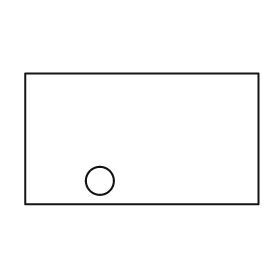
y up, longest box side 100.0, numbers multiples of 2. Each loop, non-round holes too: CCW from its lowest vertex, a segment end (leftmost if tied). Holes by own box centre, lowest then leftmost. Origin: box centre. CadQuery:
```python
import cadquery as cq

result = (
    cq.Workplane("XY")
    .moveTo(-50.0, -28.0)
    .lineTo(50.0, -28.0)
    .lineTo(50.0, 28.0)
    .lineTo(-50.0, 28.0)
    .close()
    .moveTo(-18.0, -18.0)
    .circle(6.0)
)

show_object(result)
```